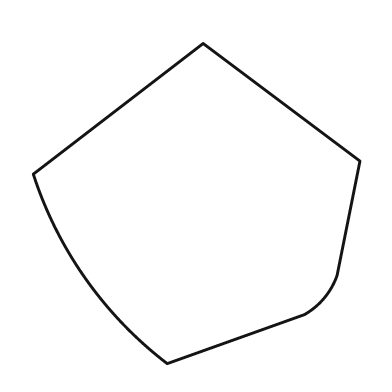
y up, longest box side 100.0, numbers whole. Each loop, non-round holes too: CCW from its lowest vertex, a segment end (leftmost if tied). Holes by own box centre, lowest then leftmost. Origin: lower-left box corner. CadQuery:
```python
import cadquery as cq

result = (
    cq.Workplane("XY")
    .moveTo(41.0, 0.0)
    .lineTo(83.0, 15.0)
    .threePointArc((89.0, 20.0), (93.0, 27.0))
    .lineTo(100.0, 62.0)
    .lineTo(52.0, 98.0)
    .lineTo(0.0, 58.0)
    .threePointArc((16.0, 26.0), (41.0, 0.0))
    .close()
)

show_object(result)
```